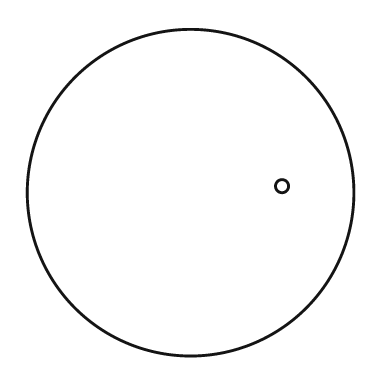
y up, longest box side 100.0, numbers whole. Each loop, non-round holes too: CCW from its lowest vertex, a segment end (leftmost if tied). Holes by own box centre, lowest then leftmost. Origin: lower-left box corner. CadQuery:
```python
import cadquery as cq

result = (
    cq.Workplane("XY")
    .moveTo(50.0, 50.0)
    .circle(50.0)
    .moveTo(78.0, 52.0)
    .circle(2.0)
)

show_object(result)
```